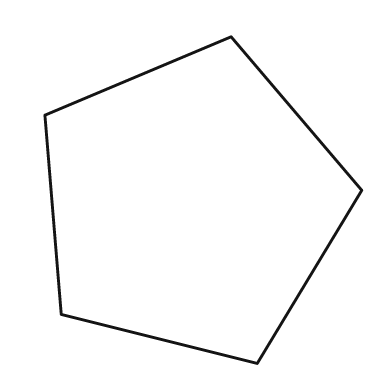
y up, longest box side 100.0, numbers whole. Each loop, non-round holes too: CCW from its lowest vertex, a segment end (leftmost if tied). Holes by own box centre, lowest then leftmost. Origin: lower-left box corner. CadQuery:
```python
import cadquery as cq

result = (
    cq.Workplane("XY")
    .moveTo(65.0, 0.0)
    .lineTo(97.0, 53.0)
    .lineTo(57.0, 100.0)
    .lineTo(0.0, 76.0)
    .lineTo(5.0, 15.0)
    .close()
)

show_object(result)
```